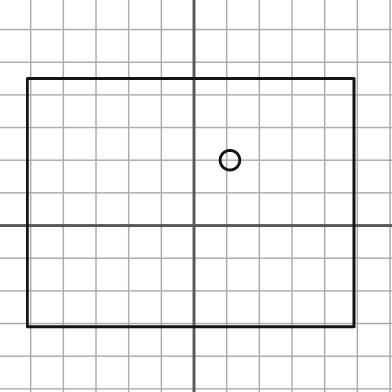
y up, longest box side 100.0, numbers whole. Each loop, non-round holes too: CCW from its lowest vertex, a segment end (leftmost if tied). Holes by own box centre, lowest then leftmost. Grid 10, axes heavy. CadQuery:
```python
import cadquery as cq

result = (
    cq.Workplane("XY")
    .moveTo(-51.0, -31.0)
    .lineTo(49.0, -31.0)
    .lineTo(49.0, 45.0)
    .lineTo(-51.0, 45.0)
    .close()
    .moveTo(11.0, 20.0)
    .circle(3.0)
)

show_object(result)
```